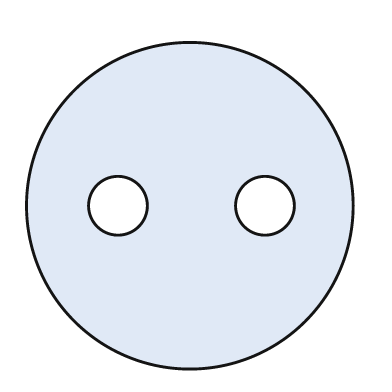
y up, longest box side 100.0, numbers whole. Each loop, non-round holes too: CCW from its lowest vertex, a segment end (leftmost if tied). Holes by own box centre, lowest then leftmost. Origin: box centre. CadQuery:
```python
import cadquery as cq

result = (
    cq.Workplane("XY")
    .moveTo(0.0, 0.0)
    .circle(50.0)
    .moveTo(-22.0, 0.0)
    .circle(9.0)
    .moveTo(23.0, 0.0)
    .circle(9.0)
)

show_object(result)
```